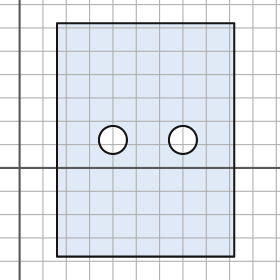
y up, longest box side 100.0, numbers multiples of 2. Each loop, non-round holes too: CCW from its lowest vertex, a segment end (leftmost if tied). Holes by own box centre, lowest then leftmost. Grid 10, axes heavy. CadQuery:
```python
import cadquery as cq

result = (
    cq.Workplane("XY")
    .moveTo(16.0, -38.0)
    .lineTo(92.0, -38.0)
    .lineTo(92.0, 62.0)
    .lineTo(16.0, 62.0)
    .close()
    .moveTo(40.0, 12.0)
    .circle(6.0)
    .moveTo(70.0, 12.0)
    .circle(6.0)
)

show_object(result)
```